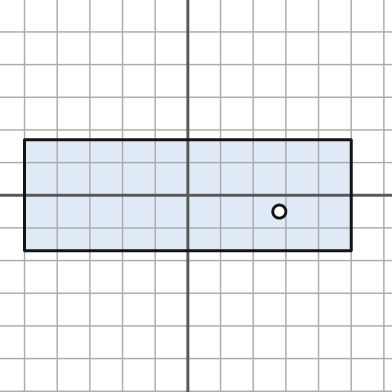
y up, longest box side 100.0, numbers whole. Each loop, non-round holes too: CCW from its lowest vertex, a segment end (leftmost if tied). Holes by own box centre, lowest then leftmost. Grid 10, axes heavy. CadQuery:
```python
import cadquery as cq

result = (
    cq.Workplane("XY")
    .moveTo(-50.0, -17.0)
    .lineTo(50.0, -17.0)
    .lineTo(50.0, 17.0)
    .lineTo(-50.0, 17.0)
    .close()
    .moveTo(28.0, -5.0)
    .circle(2.0)
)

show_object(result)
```